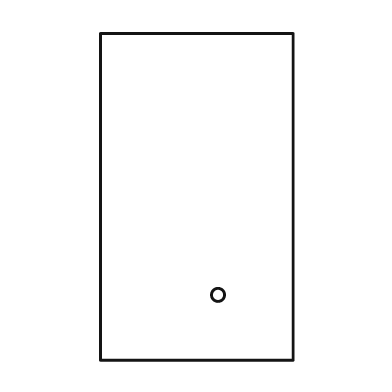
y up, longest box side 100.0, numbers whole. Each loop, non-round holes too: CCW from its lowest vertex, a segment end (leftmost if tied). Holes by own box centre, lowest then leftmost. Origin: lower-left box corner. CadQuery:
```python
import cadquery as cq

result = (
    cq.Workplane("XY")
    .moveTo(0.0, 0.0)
    .lineTo(59.0, 0.0)
    .lineTo(59.0, 100.0)
    .lineTo(0.0, 100.0)
    .close()
    .moveTo(36.0, 20.0)
    .circle(2.0)
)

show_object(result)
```